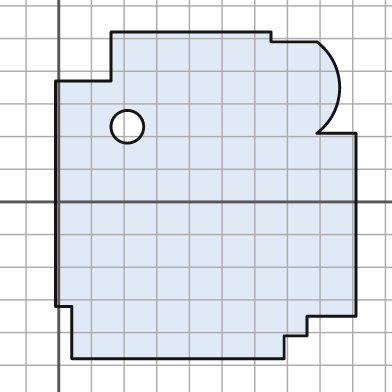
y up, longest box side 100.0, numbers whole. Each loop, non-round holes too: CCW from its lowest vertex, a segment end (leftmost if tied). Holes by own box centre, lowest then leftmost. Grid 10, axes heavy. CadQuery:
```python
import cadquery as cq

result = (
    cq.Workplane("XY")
    .moveTo(4.0, -48.0)
    .lineTo(69.0, -48.0)
    .lineTo(69.0, -41.0)
    .lineTo(76.0, -41.0)
    .lineTo(76.0, -35.0)
    .lineTo(91.0, -35.0)
    .lineTo(91.0, 21.0)
    .lineTo(79.0, 21.0)
    .threePointArc((86.0, 35.0), (79.0, 49.0))
    .lineTo(65.0, 49.0)
    .lineTo(65.0, 52.0)
    .lineTo(16.0, 52.0)
    .lineTo(16.0, 37.0)
    .lineTo(-1.0, 37.0)
    .lineTo(-1.0, -32.0)
    .lineTo(4.0, -32.0)
    .close()
    .moveTo(21.0, 23.0)
    .circle(5.0)
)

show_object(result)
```